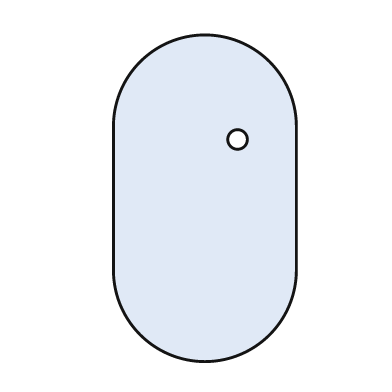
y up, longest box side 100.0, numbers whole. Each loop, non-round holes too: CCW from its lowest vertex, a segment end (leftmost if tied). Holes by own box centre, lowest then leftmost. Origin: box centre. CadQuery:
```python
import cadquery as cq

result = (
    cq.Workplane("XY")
    .moveTo(-28.0, -22.0)
    .threePointArc((0.0, -50.0), (28.0, -22.0))
    .lineTo(28.0, 22.0)
    .threePointArc((0.0, 50.0), (-28.0, 22.0))
    .close()
    .moveTo(10.0, 18.0)
    .circle(3.0)
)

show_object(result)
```